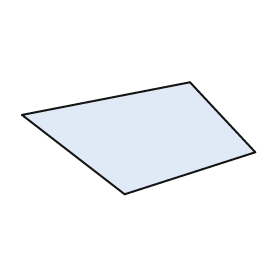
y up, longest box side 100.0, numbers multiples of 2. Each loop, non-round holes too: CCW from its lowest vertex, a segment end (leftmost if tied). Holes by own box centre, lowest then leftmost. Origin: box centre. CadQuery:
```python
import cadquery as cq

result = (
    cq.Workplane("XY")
    .moveTo(-6.0, -24.0)
    .lineTo(50.0, -6.0)
    .lineTo(22.0, 24.0)
    .lineTo(-50.0, 10.0)
    .close()
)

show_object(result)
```